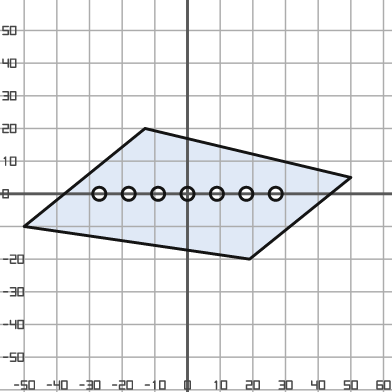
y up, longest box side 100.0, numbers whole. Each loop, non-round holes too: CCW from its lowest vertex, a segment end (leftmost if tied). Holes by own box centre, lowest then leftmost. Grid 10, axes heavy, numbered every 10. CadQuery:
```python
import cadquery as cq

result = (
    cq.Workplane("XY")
    .moveTo(19.0, -20.0)
    .lineTo(50.0, 5.0)
    .lineTo(-13.0, 20.0)
    .lineTo(-50.0, -10.0)
    .close()
    .moveTo(-27.0, 0.0)
    .circle(2.0)
    .moveTo(-18.0, 0.0)
    .circle(2.0)
    .moveTo(-9.0, 0.0)
    .circle(2.0)
    .moveTo(0.0, 0.0)
    .circle(2.0)
    .moveTo(9.0, 0.0)
    .circle(2.0)
    .moveTo(18.0, 0.0)
    .circle(2.0)
    .moveTo(27.0, 0.0)
    .circle(2.0)
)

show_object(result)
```